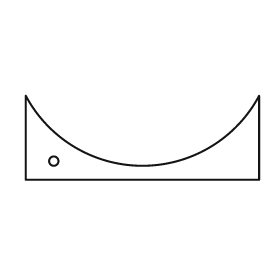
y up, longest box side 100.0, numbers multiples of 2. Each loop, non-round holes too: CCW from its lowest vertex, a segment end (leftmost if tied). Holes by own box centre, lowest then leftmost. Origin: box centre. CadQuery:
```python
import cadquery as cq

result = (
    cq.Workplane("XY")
    .moveTo(-50.0, -18.0)
    .lineTo(50.0, -18.0)
    .lineTo(50.0, 18.0)
    .threePointArc((0.0, -12.0), (-50.0, 18.0))
    .close()
    .moveTo(-38.0, -10.0)
    .circle(2.0)
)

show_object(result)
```